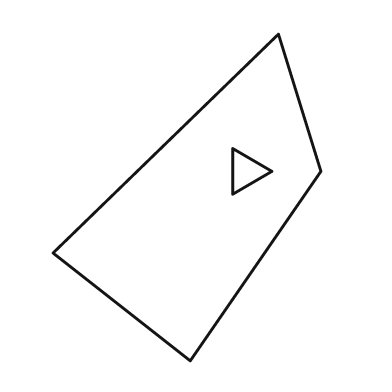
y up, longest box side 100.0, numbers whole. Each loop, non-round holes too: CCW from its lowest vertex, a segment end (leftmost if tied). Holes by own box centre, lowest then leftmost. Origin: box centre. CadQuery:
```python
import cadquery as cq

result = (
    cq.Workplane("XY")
    .moveTo(1.0, -50.0)
    .lineTo(41.0, 8.0)
    .lineTo(28.0, 50.0)
    .lineTo(-41.0, -17.0)
    .close()
    .moveTo(14.0, 1.0)
    .lineTo(26.0, 8.0)
    .lineTo(14.0, 15.0)
    .close()
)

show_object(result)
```